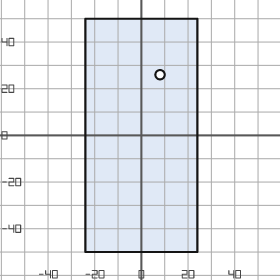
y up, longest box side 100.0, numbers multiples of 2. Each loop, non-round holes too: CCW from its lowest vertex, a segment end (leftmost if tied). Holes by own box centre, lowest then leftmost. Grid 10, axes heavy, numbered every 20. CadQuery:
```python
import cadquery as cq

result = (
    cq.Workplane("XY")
    .moveTo(-24.0, -50.0)
    .lineTo(24.0, -50.0)
    .lineTo(24.0, 50.0)
    .lineTo(-24.0, 50.0)
    .close()
    .moveTo(8.0, 26.0)
    .circle(2.0)
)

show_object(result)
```